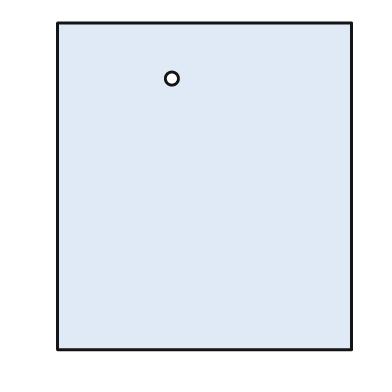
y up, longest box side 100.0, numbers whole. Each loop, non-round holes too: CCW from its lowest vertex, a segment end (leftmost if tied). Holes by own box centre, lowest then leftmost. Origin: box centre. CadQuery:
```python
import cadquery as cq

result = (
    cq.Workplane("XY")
    .moveTo(-45.0, -50.0)
    .lineTo(45.0, -50.0)
    .lineTo(45.0, 50.0)
    .lineTo(-45.0, 50.0)
    .close()
    .moveTo(-10.0, 33.0)
    .circle(2.0)
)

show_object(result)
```